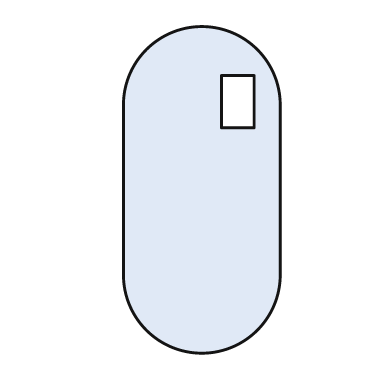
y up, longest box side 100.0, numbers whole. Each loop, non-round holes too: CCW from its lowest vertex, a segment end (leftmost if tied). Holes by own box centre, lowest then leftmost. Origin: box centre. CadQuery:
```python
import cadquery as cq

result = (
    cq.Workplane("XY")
    .moveTo(-24.0, -26.0)
    .threePointArc((0.0, -50.0), (24.0, -26.0))
    .lineTo(24.0, 26.0)
    .threePointArc((0.0, 50.0), (-24.0, 26.0))
    .close()
    .moveTo(6.0, 19.0)
    .lineTo(16.0, 19.0)
    .lineTo(16.0, 35.0)
    .lineTo(6.0, 35.0)
    .close()
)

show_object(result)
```